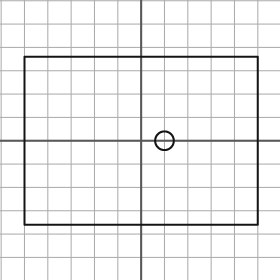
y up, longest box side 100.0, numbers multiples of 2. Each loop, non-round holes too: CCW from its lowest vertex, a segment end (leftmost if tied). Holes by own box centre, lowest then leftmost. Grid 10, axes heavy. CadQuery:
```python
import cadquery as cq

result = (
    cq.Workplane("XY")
    .moveTo(-50.0, -36.0)
    .lineTo(50.0, -36.0)
    .lineTo(50.0, 36.0)
    .lineTo(-50.0, 36.0)
    .close()
    .moveTo(10.0, 0.0)
    .circle(4.0)
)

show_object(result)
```